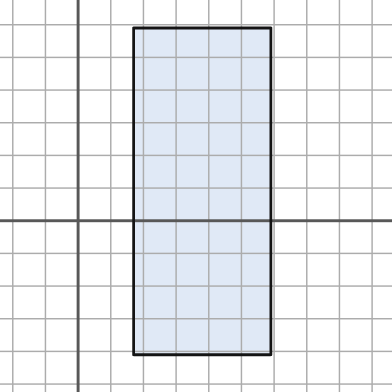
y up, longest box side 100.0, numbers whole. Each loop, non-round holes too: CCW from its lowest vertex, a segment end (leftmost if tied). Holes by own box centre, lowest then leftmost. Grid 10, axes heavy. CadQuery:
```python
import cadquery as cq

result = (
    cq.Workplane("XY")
    .moveTo(17.0, -41.0)
    .lineTo(59.0, -41.0)
    .lineTo(59.0, 59.0)
    .lineTo(17.0, 59.0)
    .close()
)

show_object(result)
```